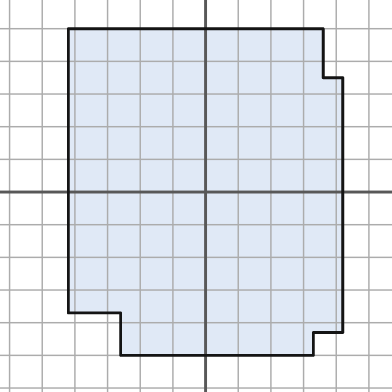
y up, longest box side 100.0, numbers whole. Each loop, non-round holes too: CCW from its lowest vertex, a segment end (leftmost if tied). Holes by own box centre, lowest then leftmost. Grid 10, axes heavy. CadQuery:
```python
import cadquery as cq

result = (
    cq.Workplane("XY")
    .moveTo(-26.0, -50.0)
    .lineTo(33.0, -50.0)
    .lineTo(33.0, -43.0)
    .lineTo(42.0, -43.0)
    .lineTo(42.0, 35.0)
    .lineTo(36.0, 35.0)
    .lineTo(36.0, 50.0)
    .lineTo(-42.0, 50.0)
    .lineTo(-42.0, -37.0)
    .lineTo(-26.0, -37.0)
    .close()
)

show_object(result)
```